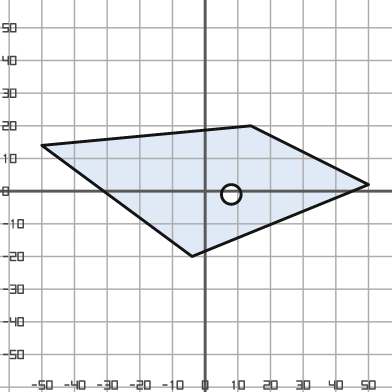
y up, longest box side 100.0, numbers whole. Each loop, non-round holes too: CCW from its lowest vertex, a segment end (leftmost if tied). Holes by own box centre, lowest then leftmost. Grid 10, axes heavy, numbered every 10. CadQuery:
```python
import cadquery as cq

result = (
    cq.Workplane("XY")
    .moveTo(-4.0, -20.0)
    .lineTo(50.0, 2.0)
    .lineTo(14.0, 20.0)
    .lineTo(-50.0, 14.0)
    .close()
    .moveTo(8.0, -1.0)
    .circle(3.0)
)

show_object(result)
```